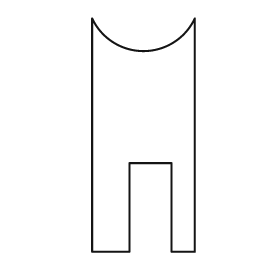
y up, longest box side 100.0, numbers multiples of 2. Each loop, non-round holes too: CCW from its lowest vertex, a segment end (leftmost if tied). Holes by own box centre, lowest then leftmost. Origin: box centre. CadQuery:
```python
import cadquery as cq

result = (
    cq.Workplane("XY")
    .moveTo(-22.0, -50.0)
    .lineTo(-6.0, -50.0)
    .lineTo(-6.0, -12.0)
    .lineTo(12.0, -12.0)
    .lineTo(12.0, -50.0)
    .lineTo(22.0, -50.0)
    .lineTo(22.0, 50.0)
    .threePointArc((0.0, 36.0), (-22.0, 50.0))
    .close()
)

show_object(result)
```